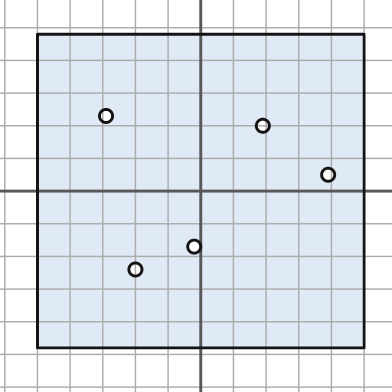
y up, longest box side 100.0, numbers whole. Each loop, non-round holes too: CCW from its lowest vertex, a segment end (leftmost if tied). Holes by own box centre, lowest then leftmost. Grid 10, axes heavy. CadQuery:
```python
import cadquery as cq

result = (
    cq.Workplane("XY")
    .moveTo(-50.0, -48.0)
    .lineTo(50.0, -48.0)
    .lineTo(50.0, 48.0)
    .lineTo(-50.0, 48.0)
    .close()
    .moveTo(-20.0, -24.0)
    .circle(2.0)
    .moveTo(-2.0, -17.0)
    .circle(2.0)
    .moveTo(39.0, 5.0)
    .circle(2.0)
    .moveTo(19.0, 20.0)
    .circle(2.0)
    .moveTo(-29.0, 23.0)
    .circle(2.0)
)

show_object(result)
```